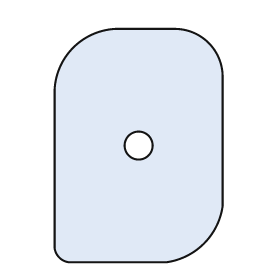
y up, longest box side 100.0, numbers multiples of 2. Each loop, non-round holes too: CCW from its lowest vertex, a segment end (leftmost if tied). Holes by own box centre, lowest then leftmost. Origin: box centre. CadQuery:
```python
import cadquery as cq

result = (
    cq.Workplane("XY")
    .moveTo(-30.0, -50.0)
    .lineTo(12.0, -50.0)
    .threePointArc((28.0, -42.0), (36.0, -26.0))
    .lineTo(36.0, 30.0)
    .threePointArc((30.0, 44.0), (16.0, 50.0))
    .lineTo(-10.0, 50.0)
    .threePointArc((-28.0, 42.0), (-36.0, 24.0))
    .lineTo(-36.0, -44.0)
    .threePointArc((-34.0, -48.0), (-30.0, -50.0))
    .close()
    .moveTo(0.0, 0.0)
    .circle(6.0)
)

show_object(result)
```